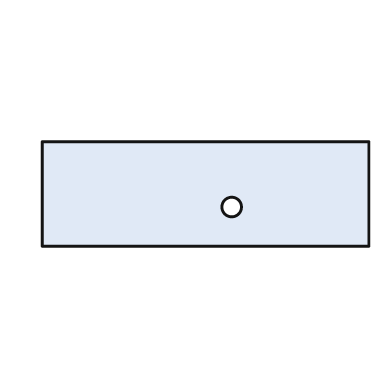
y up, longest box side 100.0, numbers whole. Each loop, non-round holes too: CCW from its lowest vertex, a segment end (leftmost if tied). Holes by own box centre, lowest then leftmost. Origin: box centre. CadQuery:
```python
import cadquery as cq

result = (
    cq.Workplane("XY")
    .moveTo(-50.0, -16.0)
    .lineTo(50.0, -16.0)
    .lineTo(50.0, 16.0)
    .lineTo(-50.0, 16.0)
    .close()
    .moveTo(8.0, -4.0)
    .circle(3.0)
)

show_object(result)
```